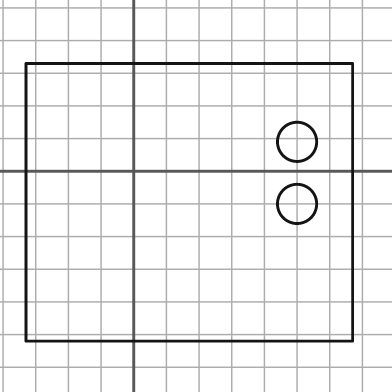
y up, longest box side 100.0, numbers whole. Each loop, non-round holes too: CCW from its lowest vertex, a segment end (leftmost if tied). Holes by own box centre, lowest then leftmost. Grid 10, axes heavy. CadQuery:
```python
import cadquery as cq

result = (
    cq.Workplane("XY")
    .moveTo(-33.0, -52.0)
    .lineTo(67.0, -52.0)
    .lineTo(67.0, 33.0)
    .lineTo(-33.0, 33.0)
    .close()
    .moveTo(50.0, -10.0)
    .circle(6.0)
    .moveTo(50.0, 9.0)
    .circle(6.0)
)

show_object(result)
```